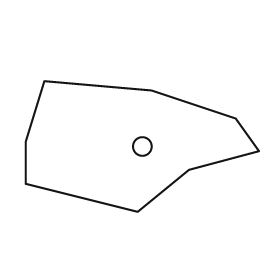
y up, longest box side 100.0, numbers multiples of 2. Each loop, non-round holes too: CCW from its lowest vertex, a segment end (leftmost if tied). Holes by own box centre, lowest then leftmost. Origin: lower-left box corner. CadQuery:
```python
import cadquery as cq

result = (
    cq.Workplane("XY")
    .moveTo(48.0, 0.0)
    .lineTo(70.0, 18.0)
    .lineTo(100.0, 26.0)
    .lineTo(90.0, 40.0)
    .lineTo(54.0, 52.0)
    .lineTo(8.0, 56.0)
    .lineTo(0.0, 30.0)
    .lineTo(0.0, 12.0)
    .close()
    .moveTo(50.0, 28.0)
    .circle(4.0)
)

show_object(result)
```